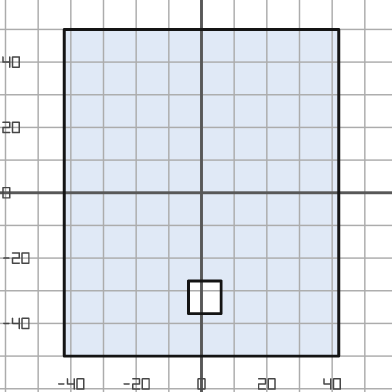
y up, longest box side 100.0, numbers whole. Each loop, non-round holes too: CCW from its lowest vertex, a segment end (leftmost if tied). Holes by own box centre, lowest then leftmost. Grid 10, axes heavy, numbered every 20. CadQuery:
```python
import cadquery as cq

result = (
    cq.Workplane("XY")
    .moveTo(-42.0, -50.0)
    .lineTo(42.0, -50.0)
    .lineTo(42.0, 50.0)
    .lineTo(-42.0, 50.0)
    .close()
    .moveTo(-4.0, -37.0)
    .lineTo(6.0, -37.0)
    .lineTo(6.0, -27.0)
    .lineTo(-4.0, -27.0)
    .close()
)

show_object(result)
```